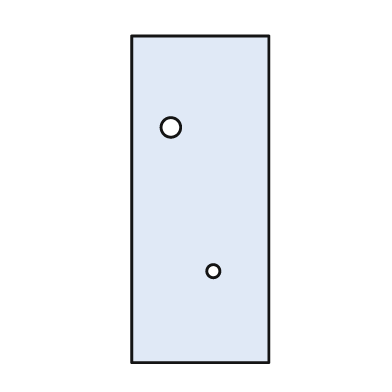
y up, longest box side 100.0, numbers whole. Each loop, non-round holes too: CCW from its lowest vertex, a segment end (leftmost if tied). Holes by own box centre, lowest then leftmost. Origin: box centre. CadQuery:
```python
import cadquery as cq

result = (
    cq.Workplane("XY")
    .moveTo(-21.0, -50.0)
    .lineTo(21.0, -50.0)
    .lineTo(21.0, 50.0)
    .lineTo(-21.0, 50.0)
    .close()
    .moveTo(4.0, -22.0)
    .circle(2.0)
    .moveTo(-9.0, 22.0)
    .circle(3.0)
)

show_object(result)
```